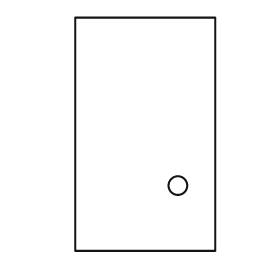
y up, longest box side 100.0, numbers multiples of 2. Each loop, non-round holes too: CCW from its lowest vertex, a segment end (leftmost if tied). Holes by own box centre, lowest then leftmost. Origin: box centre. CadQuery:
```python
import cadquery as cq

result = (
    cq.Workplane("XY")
    .moveTo(-30.0, -50.0)
    .lineTo(30.0, -50.0)
    .lineTo(30.0, 50.0)
    .lineTo(-30.0, 50.0)
    .close()
    .moveTo(14.0, -22.0)
    .circle(4.0)
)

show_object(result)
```